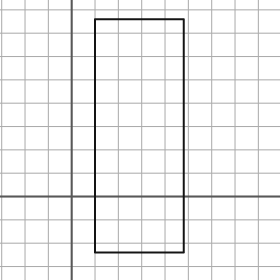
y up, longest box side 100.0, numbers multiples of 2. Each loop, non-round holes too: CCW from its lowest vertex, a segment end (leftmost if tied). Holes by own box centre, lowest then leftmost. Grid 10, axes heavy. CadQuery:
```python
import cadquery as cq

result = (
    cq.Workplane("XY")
    .moveTo(10.0, -24.0)
    .lineTo(48.0, -24.0)
    .lineTo(48.0, 76.0)
    .lineTo(10.0, 76.0)
    .close()
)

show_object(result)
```